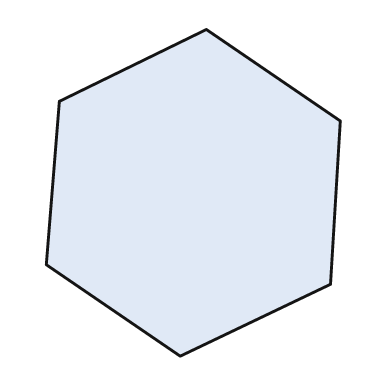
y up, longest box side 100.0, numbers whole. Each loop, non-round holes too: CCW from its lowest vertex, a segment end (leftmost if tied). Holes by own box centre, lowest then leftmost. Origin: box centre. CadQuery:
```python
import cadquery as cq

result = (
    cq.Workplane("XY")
    .moveTo(-4.0, -50.0)
    .lineTo(42.0, -28.0)
    .lineTo(45.0, 22.0)
    .lineTo(4.0, 50.0)
    .lineTo(-41.0, 28.0)
    .lineTo(-45.0, -22.0)
    .close()
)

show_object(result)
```